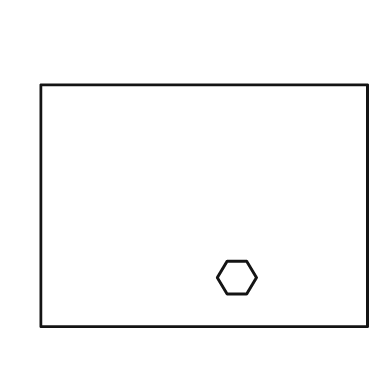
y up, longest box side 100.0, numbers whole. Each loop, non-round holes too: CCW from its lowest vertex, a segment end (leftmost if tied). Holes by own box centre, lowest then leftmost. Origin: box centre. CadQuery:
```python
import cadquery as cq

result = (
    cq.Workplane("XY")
    .moveTo(-50.0, -37.0)
    .lineTo(50.0, -37.0)
    .lineTo(50.0, 37.0)
    .lineTo(-50.0, 37.0)
    .close()
    .moveTo(7.0, -27.0)
    .lineTo(13.0, -27.0)
    .lineTo(16.0, -22.0)
    .lineTo(13.0, -17.0)
    .lineTo(7.0, -17.0)
    .lineTo(4.0, -22.0)
    .close()
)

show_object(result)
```